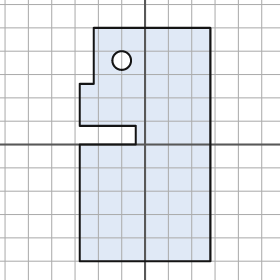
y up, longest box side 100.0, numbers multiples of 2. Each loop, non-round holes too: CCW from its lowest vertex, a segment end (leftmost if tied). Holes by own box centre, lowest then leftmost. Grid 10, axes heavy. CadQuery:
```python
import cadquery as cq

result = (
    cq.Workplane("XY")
    .moveTo(-28.0, -50.0)
    .lineTo(28.0, -50.0)
    .lineTo(28.0, 50.0)
    .lineTo(-22.0, 50.0)
    .lineTo(-22.0, 26.0)
    .lineTo(-28.0, 26.0)
    .lineTo(-28.0, 8.0)
    .lineTo(-4.0, 8.0)
    .lineTo(-4.0, 0.0)
    .lineTo(-28.0, 0.0)
    .close()
    .moveTo(-10.0, 36.0)
    .circle(4.0)
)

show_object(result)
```